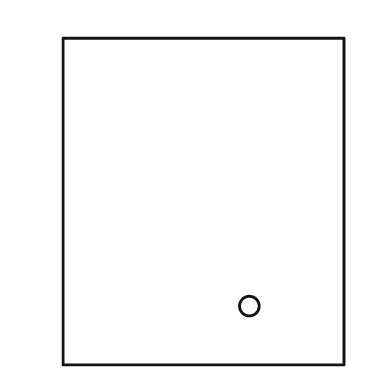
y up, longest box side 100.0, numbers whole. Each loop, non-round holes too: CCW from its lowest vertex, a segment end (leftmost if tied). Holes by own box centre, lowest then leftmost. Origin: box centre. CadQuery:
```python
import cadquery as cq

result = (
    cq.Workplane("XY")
    .moveTo(-43.0, -50.0)
    .lineTo(43.0, -50.0)
    .lineTo(43.0, 50.0)
    .lineTo(-43.0, 50.0)
    .close()
    .moveTo(14.0, -32.0)
    .circle(3.0)
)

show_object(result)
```